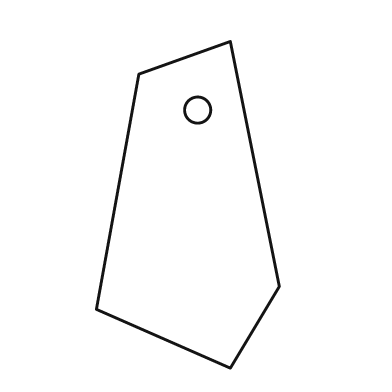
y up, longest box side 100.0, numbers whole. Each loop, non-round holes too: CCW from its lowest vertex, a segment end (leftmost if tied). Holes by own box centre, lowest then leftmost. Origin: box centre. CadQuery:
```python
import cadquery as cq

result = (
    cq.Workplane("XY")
    .moveTo(13.0, -50.0)
    .lineTo(28.0, -25.0)
    .lineTo(13.0, 50.0)
    .lineTo(-15.0, 40.0)
    .lineTo(-28.0, -32.0)
    .close()
    .moveTo(3.0, 29.0)
    .circle(4.0)
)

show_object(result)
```